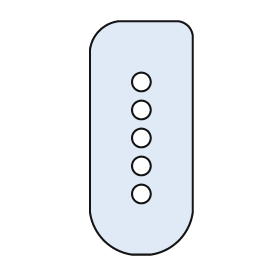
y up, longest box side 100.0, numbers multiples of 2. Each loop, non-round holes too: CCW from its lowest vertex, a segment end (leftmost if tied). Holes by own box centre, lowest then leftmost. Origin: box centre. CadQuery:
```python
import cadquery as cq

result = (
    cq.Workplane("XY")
    .moveTo(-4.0, -50.0)
    .lineTo(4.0, -50.0)
    .threePointArc((16.0, -44.0), (22.0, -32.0))
    .lineTo(22.0, 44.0)
    .threePointArc((20.0, 48.0), (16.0, 50.0))
    .lineTo(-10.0, 50.0)
    .threePointArc((-18.0, 46.0), (-22.0, 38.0))
    .lineTo(-22.0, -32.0)
    .threePointArc((-16.0, -44.0), (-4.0, -50.0))
    .close()
    .moveTo(0.0, -24.0)
    .circle(4.0)
    .moveTo(0.0, -12.0)
    .circle(4.0)
    .moveTo(0.0, 0.0)
    .circle(4.0)
    .moveTo(0.0, 12.0)
    .circle(4.0)
    .moveTo(0.0, 24.0)
    .circle(4.0)
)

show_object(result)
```